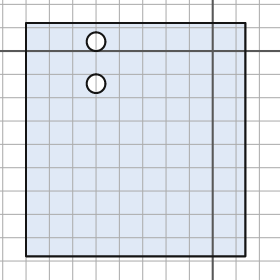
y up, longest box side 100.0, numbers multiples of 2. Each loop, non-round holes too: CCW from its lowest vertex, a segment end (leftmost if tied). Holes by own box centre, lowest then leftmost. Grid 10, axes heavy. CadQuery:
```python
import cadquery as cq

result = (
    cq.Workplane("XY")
    .moveTo(-80.0, -88.0)
    .lineTo(14.0, -88.0)
    .lineTo(14.0, 12.0)
    .lineTo(-80.0, 12.0)
    .close()
    .moveTo(-50.0, -14.0)
    .circle(4.0)
    .moveTo(-50.0, 4.0)
    .circle(4.0)
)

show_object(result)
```